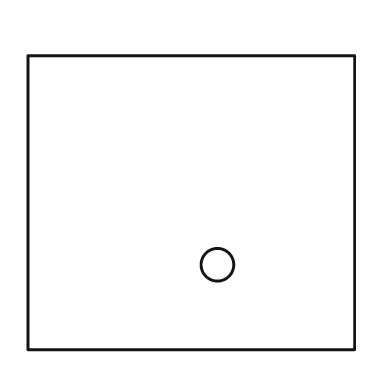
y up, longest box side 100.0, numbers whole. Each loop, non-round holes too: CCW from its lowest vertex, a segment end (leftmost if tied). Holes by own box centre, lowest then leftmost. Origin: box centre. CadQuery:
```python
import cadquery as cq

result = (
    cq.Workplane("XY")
    .moveTo(-50.0, -45.0)
    .lineTo(50.0, -45.0)
    .lineTo(50.0, 45.0)
    .lineTo(-50.0, 45.0)
    .close()
    .moveTo(8.0, -19.0)
    .circle(5.0)
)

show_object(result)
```